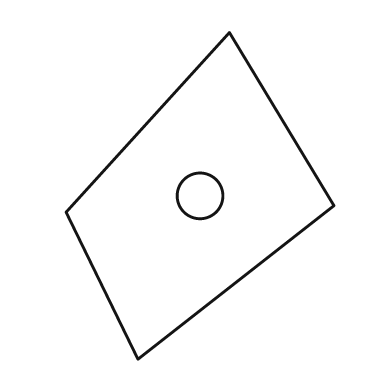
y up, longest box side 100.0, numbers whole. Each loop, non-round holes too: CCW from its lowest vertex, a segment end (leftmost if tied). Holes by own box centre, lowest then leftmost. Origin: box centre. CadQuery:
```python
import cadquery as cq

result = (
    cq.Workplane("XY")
    .moveTo(-19.0, -50.0)
    .lineTo(41.0, -3.0)
    .lineTo(9.0, 50.0)
    .lineTo(-41.0, -5.0)
    .close()
    .moveTo(0.0, 0.0)
    .circle(7.0)
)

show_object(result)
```